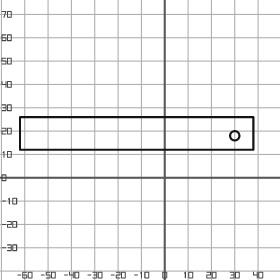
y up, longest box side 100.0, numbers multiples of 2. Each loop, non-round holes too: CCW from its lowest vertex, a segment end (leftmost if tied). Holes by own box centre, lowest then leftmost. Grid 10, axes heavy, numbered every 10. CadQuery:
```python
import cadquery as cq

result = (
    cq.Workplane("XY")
    .moveTo(-62.0, 12.0)
    .lineTo(38.0, 12.0)
    .lineTo(38.0, 26.0)
    .lineTo(-62.0, 26.0)
    .close()
    .moveTo(30.0, 18.0)
    .circle(2.0)
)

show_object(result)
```